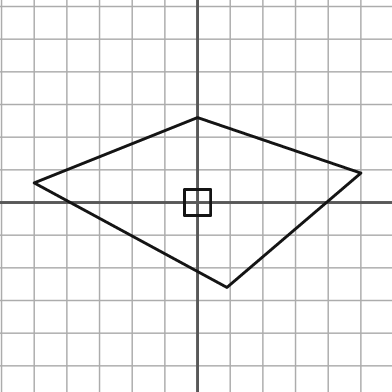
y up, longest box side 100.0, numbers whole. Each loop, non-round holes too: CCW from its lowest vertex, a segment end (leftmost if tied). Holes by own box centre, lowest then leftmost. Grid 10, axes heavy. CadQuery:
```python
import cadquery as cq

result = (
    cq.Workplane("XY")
    .moveTo(9.0, -26.0)
    .lineTo(50.0, 9.0)
    .lineTo(0.0, 26.0)
    .lineTo(-50.0, 6.0)
    .close()
    .moveTo(-4.0, -4.0)
    .lineTo(4.0, -4.0)
    .lineTo(4.0, 4.0)
    .lineTo(-4.0, 4.0)
    .close()
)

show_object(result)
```